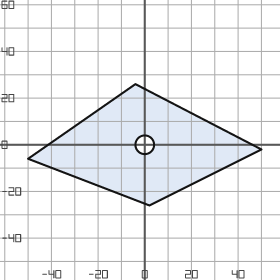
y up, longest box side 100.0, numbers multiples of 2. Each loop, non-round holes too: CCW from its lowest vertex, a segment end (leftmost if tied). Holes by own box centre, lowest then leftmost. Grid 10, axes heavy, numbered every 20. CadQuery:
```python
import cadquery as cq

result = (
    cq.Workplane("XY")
    .moveTo(2.0, -26.0)
    .lineTo(50.0, -2.0)
    .lineTo(-4.0, 26.0)
    .lineTo(-50.0, -6.0)
    .close()
    .moveTo(0.0, 0.0)
    .circle(4.0)
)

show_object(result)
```